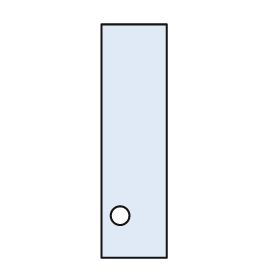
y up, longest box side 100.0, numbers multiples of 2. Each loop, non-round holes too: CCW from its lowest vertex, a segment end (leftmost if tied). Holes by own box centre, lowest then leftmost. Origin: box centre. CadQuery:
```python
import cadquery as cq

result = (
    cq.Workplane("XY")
    .moveTo(-14.0, -50.0)
    .lineTo(14.0, -50.0)
    .lineTo(14.0, 50.0)
    .lineTo(-14.0, 50.0)
    .close()
    .moveTo(-6.0, -32.0)
    .circle(4.0)
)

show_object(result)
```